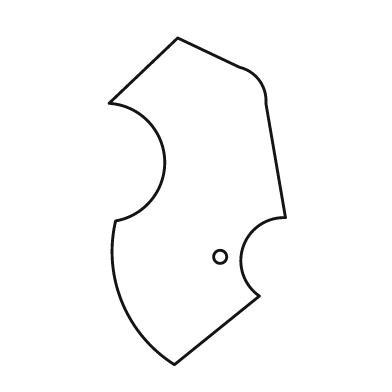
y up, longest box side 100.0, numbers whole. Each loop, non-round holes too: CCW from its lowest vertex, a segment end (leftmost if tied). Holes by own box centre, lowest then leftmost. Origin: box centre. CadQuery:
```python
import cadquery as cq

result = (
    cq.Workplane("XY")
    .moveTo(-7.0, -50.0)
    .lineTo(19.0, -29.0)
    .threePointArc((14.0, -14.0), (27.0, -5.0))
    .lineTo(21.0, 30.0)
    .threePointArc((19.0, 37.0), (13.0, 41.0))
    .lineTo(-6.0, 50.0)
    .lineTo(-27.0, 30.0)
    .threePointArc((-10.0, 13.0), (-25.0, -6.0))
    .threePointArc((-23.0, -31.0), (-7.0, -50.0))
    .close()
    .moveTo(7.0, -17.0)
    .circle(2.0)
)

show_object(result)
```